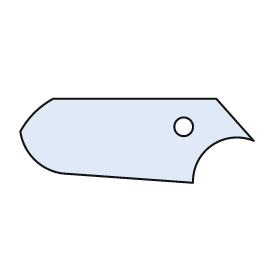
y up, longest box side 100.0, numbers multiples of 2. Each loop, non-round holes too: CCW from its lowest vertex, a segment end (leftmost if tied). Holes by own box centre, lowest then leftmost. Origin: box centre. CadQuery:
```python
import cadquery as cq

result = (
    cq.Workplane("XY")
    .moveTo(24.0, -18.0)
    .threePointArc((32.0, -2.0), (50.0, 0.0))
    .lineTo(34.0, 18.0)
    .lineTo(-36.0, 18.0)
    .threePointArc((-44.0, 12.0), (-50.0, 4.0))
    .threePointArc((-44.0, -8.0), (-32.0, -14.0))
    .close()
    .moveTo(20.0, 6.0)
    .circle(4.0)
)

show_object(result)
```